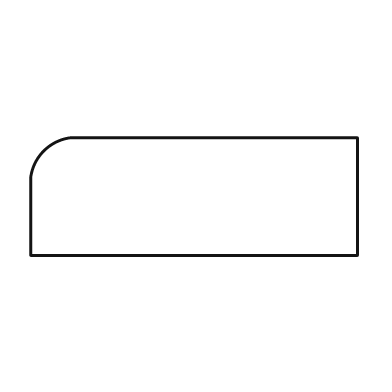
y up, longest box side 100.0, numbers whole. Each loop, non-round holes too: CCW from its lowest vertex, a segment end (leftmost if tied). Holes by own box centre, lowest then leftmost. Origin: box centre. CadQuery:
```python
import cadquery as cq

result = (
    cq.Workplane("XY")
    .moveTo(-50.0, -18.0)
    .lineTo(50.0, -18.0)
    .lineTo(50.0, 18.0)
    .lineTo(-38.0, 18.0)
    .threePointArc((-46.0, 14.0), (-50.0, 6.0))
    .close()
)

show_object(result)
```